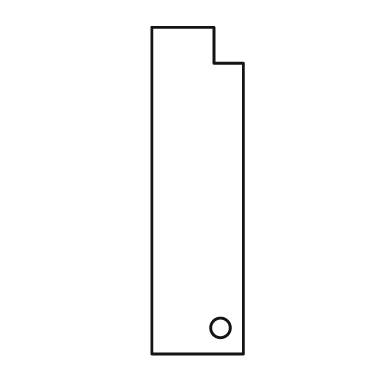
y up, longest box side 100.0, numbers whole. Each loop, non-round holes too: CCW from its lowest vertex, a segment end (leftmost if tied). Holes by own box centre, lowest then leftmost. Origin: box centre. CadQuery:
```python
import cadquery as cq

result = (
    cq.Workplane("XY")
    .moveTo(-14.0, -50.0)
    .lineTo(14.0, -50.0)
    .lineTo(14.0, 39.0)
    .lineTo(5.0, 39.0)
    .lineTo(5.0, 50.0)
    .lineTo(-14.0, 50.0)
    .close()
    .moveTo(7.0, -42.0)
    .circle(3.0)
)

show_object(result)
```